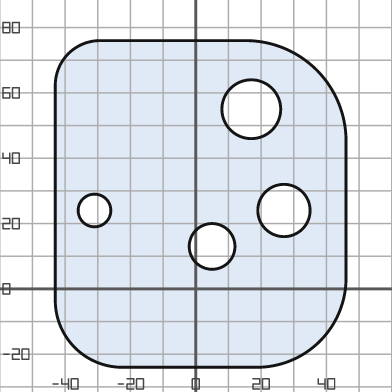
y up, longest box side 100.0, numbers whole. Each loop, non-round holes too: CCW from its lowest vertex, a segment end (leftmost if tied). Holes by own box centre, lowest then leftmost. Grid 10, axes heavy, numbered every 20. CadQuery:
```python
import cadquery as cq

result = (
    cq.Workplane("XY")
    .moveTo(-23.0, -24.0)
    .lineTo(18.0, -24.0)
    .threePointArc((38.0, -16.0), (46.0, 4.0))
    .lineTo(46.0, 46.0)
    .threePointArc((37.0, 67.0), (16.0, 76.0))
    .lineTo(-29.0, 76.0)
    .threePointArc((-39.0, 72.0), (-43.0, 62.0))
    .lineTo(-43.0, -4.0)
    .threePointArc((-37.0, -18.0), (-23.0, -24.0))
    .close()
    .moveTo(5.0, 13.0)
    .circle(7.0)
    .moveTo(-31.0, 24.0)
    .circle(5.0)
    .moveTo(27.0, 24.0)
    .circle(8.0)
    .moveTo(17.0, 55.0)
    .circle(9.0)
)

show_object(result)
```